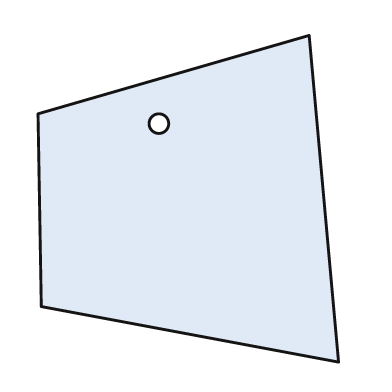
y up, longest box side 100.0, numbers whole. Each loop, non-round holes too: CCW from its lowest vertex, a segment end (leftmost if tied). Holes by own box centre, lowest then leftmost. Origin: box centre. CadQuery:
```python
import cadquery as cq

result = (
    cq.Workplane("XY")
    .moveTo(46.0, -50.0)
    .lineTo(37.0, 50.0)
    .lineTo(-46.0, 26.0)
    .lineTo(-45.0, -33.0)
    .close()
    .moveTo(-9.0, 23.0)
    .circle(3.0)
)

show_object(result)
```